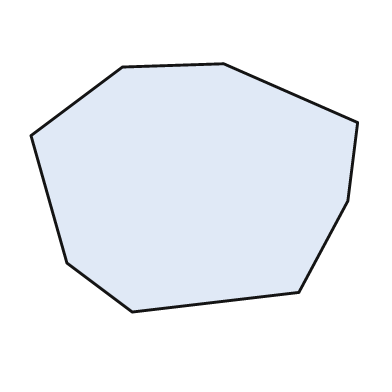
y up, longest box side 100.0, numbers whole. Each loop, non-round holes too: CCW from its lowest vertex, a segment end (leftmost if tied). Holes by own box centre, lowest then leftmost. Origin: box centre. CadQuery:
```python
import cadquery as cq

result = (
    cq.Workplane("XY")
    .moveTo(-19.0, -38.0)
    .lineTo(32.0, -32.0)
    .lineTo(47.0, -4.0)
    .lineTo(50.0, 20.0)
    .lineTo(9.0, 38.0)
    .lineTo(-22.0, 37.0)
    .lineTo(-50.0, 16.0)
    .lineTo(-39.0, -23.0)
    .close()
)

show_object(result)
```